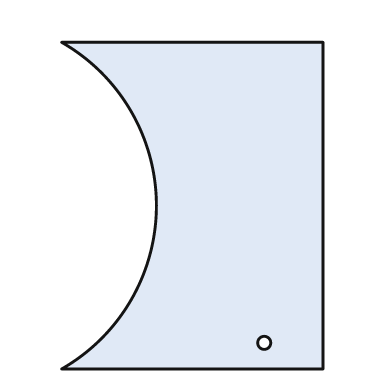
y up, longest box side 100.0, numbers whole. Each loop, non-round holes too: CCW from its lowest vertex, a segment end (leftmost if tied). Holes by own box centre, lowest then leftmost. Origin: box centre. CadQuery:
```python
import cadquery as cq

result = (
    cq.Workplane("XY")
    .moveTo(-40.0, -50.0)
    .lineTo(40.0, -50.0)
    .lineTo(40.0, 50.0)
    .lineTo(-40.0, 50.0)
    .threePointArc((-11.0, 0.0), (-40.0, -50.0))
    .close()
    .moveTo(22.0, -42.0)
    .circle(2.0)
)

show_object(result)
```